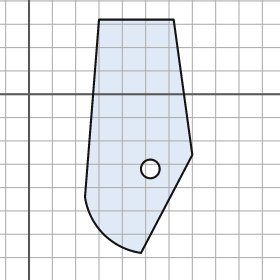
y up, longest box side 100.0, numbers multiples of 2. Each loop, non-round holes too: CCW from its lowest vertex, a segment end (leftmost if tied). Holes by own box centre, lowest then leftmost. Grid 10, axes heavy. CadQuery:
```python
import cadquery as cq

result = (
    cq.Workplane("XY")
    .moveTo(48.0, -68.0)
    .lineTo(70.0, -26.0)
    .lineTo(62.0, 32.0)
    .lineTo(30.0, 32.0)
    .lineTo(24.0, -44.0)
    .threePointArc((32.0, -60.0), (48.0, -68.0))
    .close()
    .moveTo(52.0, -32.0)
    .circle(4.0)
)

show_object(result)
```